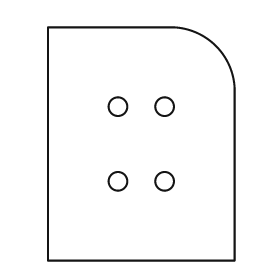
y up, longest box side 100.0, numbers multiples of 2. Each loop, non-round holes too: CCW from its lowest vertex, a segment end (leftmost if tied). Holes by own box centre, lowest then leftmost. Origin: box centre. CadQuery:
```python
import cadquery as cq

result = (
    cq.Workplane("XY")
    .moveTo(-40.0, -50.0)
    .lineTo(40.0, -50.0)
    .lineTo(40.0, 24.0)
    .threePointArc((32.0, 42.0), (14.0, 50.0))
    .lineTo(-40.0, 50.0)
    .close()
    .moveTo(-10.0, -16.0)
    .circle(4.0)
    .moveTo(10.0, -16.0)
    .circle(4.0)
    .moveTo(-10.0, 16.0)
    .circle(4.0)
    .moveTo(10.0, 16.0)
    .circle(4.0)
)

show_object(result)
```